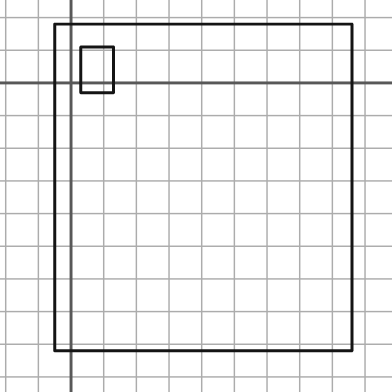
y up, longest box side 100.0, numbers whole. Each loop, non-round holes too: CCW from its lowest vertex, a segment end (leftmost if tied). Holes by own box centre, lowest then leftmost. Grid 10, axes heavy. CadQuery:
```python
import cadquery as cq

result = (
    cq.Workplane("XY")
    .moveTo(-5.0, -82.0)
    .lineTo(86.0, -82.0)
    .lineTo(86.0, 18.0)
    .lineTo(-5.0, 18.0)
    .close()
    .moveTo(3.0, -3.0)
    .lineTo(13.0, -3.0)
    .lineTo(13.0, 11.0)
    .lineTo(3.0, 11.0)
    .close()
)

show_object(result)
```